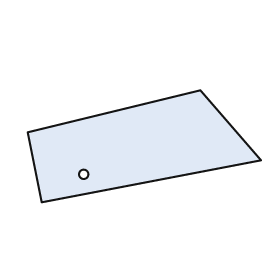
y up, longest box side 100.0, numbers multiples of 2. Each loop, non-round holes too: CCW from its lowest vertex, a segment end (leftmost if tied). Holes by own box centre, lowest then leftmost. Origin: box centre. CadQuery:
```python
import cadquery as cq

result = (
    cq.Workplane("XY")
    .moveTo(-44.0, -24.0)
    .lineTo(50.0, -6.0)
    .lineTo(24.0, 24.0)
    .lineTo(-50.0, 6.0)
    .close()
    .moveTo(-26.0, -12.0)
    .circle(2.0)
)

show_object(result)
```